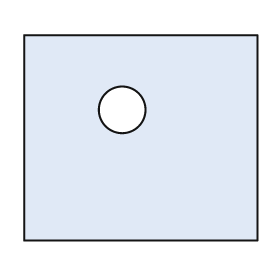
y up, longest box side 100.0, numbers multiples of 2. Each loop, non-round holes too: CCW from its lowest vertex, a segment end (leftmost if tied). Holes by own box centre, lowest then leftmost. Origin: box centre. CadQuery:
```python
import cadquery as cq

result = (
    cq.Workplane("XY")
    .moveTo(-50.0, -44.0)
    .lineTo(50.0, -44.0)
    .lineTo(50.0, 44.0)
    .lineTo(-50.0, 44.0)
    .close()
    .moveTo(-8.0, 12.0)
    .circle(10.0)
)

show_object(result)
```